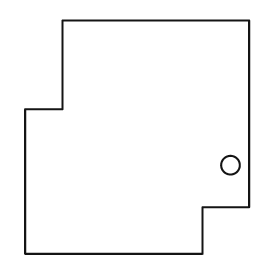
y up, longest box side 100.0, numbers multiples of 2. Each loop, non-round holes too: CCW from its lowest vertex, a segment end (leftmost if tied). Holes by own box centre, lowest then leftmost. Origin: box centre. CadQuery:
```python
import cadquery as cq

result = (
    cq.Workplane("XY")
    .moveTo(-48.0, -50.0)
    .lineTo(28.0, -50.0)
    .lineTo(28.0, -30.0)
    .lineTo(48.0, -30.0)
    .lineTo(48.0, 50.0)
    .lineTo(-32.0, 50.0)
    .lineTo(-32.0, 12.0)
    .lineTo(-48.0, 12.0)
    .close()
    .moveTo(40.0, -12.0)
    .circle(4.0)
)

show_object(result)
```